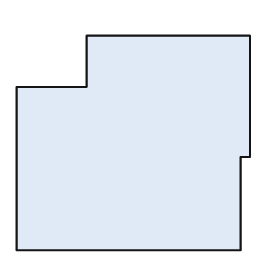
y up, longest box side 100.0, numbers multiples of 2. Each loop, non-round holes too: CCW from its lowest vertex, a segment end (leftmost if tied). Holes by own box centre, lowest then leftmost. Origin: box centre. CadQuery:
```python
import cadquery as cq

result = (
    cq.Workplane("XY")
    .moveTo(-50.0, -46.0)
    .lineTo(46.0, -46.0)
    .lineTo(46.0, -6.0)
    .lineTo(50.0, -6.0)
    .lineTo(50.0, 46.0)
    .lineTo(-20.0, 46.0)
    .lineTo(-20.0, 24.0)
    .lineTo(-50.0, 24.0)
    .close()
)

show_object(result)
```